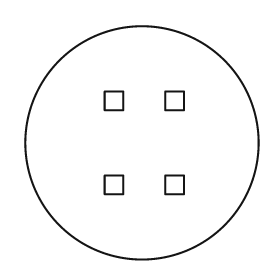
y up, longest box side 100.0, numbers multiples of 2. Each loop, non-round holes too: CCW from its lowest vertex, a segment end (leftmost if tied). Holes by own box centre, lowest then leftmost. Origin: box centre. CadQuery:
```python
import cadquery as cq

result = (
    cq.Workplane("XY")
    .moveTo(0.0, 0.0)
    .circle(50.0)
    .moveTo(-16.0, -22.0)
    .lineTo(-8.0, -22.0)
    .lineTo(-8.0, -14.0)
    .lineTo(-16.0, -14.0)
    .close()
    .moveTo(10.0, -22.0)
    .lineTo(18.0, -22.0)
    .lineTo(18.0, -14.0)
    .lineTo(10.0, -14.0)
    .close()
    .moveTo(-16.0, 14.0)
    .lineTo(-8.0, 14.0)
    .lineTo(-8.0, 22.0)
    .lineTo(-16.0, 22.0)
    .close()
    .moveTo(10.0, 14.0)
    .lineTo(18.0, 14.0)
    .lineTo(18.0, 22.0)
    .lineTo(10.0, 22.0)
    .close()
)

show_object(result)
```